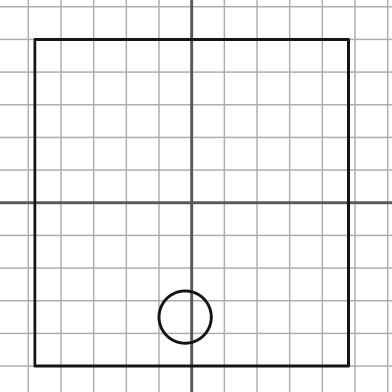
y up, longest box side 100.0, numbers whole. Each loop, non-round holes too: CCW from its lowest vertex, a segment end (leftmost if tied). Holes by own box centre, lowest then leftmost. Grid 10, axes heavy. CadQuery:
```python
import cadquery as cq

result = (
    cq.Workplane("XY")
    .moveTo(-48.0, -50.0)
    .lineTo(48.0, -50.0)
    .lineTo(48.0, 50.0)
    .lineTo(-48.0, 50.0)
    .close()
    .moveTo(-2.0, -35.0)
    .circle(8.0)
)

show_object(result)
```